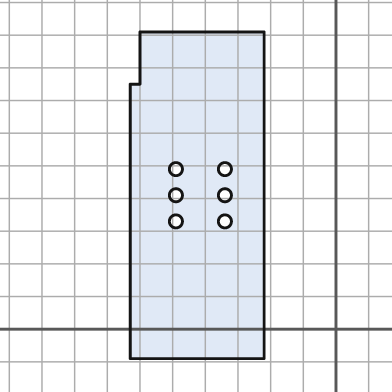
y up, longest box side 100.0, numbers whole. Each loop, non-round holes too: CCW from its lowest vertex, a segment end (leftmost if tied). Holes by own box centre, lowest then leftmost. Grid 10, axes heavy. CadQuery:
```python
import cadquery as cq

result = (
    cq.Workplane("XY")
    .moveTo(-63.0, -9.0)
    .lineTo(-22.0, -9.0)
    .lineTo(-22.0, 91.0)
    .lineTo(-60.0, 91.0)
    .lineTo(-60.0, 75.0)
    .lineTo(-63.0, 75.0)
    .close()
    .moveTo(-49.0, 33.0)
    .circle(2.0)
    .moveTo(-34.0, 33.0)
    .circle(2.0)
    .moveTo(-49.0, 41.0)
    .circle(2.0)
    .moveTo(-34.0, 41.0)
    .circle(2.0)
    .moveTo(-49.0, 49.0)
    .circle(2.0)
    .moveTo(-34.0, 49.0)
    .circle(2.0)
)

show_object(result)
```